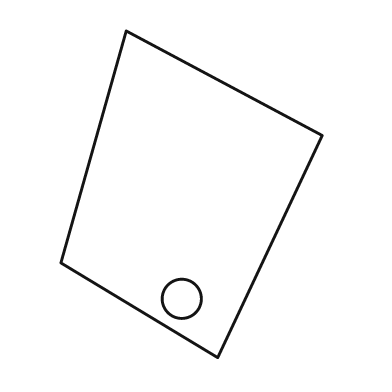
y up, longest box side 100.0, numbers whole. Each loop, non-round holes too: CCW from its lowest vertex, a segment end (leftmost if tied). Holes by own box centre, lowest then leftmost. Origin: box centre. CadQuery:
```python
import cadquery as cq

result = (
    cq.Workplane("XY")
    .moveTo(8.0, -50.0)
    .lineTo(40.0, 18.0)
    .lineTo(-20.0, 50.0)
    .lineTo(-40.0, -21.0)
    .close()
    .moveTo(-3.0, -32.0)
    .circle(6.0)
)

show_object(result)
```